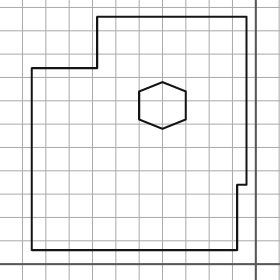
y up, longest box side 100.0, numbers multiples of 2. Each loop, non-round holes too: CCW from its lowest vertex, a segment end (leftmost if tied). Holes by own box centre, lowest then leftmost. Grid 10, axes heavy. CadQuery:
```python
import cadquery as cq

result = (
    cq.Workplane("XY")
    .moveTo(-96.0, 6.0)
    .lineTo(-8.0, 6.0)
    .lineTo(-8.0, 34.0)
    .lineTo(-4.0, 34.0)
    .lineTo(-4.0, 106.0)
    .lineTo(-68.0, 106.0)
    .lineTo(-68.0, 84.0)
    .lineTo(-96.0, 84.0)
    .close()
    .moveTo(-40.0, 58.0)
    .lineTo(-30.0, 62.0)
    .lineTo(-30.0, 74.0)
    .lineTo(-40.0, 78.0)
    .lineTo(-50.0, 74.0)
    .lineTo(-50.0, 62.0)
    .close()
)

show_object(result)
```